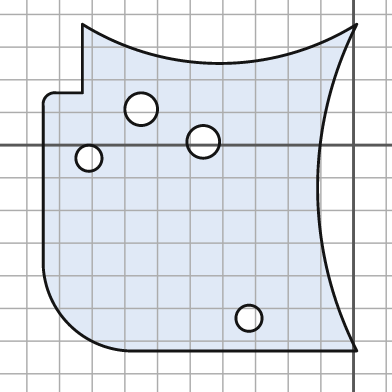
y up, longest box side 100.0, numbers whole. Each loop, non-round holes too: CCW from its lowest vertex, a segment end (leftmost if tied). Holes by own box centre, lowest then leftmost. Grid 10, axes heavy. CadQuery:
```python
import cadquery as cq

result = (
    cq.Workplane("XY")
    .moveTo(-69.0, -63.0)
    .lineTo(1.0, -63.0)
    .threePointArc((-11.0, -13.0), (1.0, 37.0))
    .threePointArc((-41.0, 25.0), (-83.0, 37.0))
    .lineTo(-83.0, 16.0)
    .lineTo(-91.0, 16.0)
    .threePointArc((-94.0, 15.0), (-95.0, 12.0))
    .lineTo(-95.0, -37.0)
    .threePointArc((-87.0, -55.0), (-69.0, -63.0))
    .close()
    .moveTo(-32.0, -53.0)
    .circle(4.0)
    .moveTo(-81.0, -4.0)
    .circle(4.0)
    .moveTo(-46.0, 1.0)
    .circle(5.0)
    .moveTo(-65.0, 11.0)
    .circle(5.0)
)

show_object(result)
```